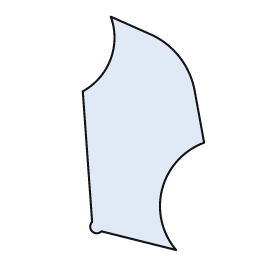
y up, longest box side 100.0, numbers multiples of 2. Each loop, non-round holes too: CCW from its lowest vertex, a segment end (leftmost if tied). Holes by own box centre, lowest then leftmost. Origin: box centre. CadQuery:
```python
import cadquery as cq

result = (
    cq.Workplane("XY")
    .moveTo(14.0, -50.0)
    .threePointArc((8.0, -24.0), (26.0, -4.0))
    .lineTo(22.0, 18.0)
    .threePointArc((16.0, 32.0), (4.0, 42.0))
    .lineTo(-14.0, 50.0)
    .threePointArc((-14.0, 32.0), (-26.0, 18.0))
    .lineTo(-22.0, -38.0)
    .threePointArc((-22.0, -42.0), (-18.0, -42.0))
    .close()
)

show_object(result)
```